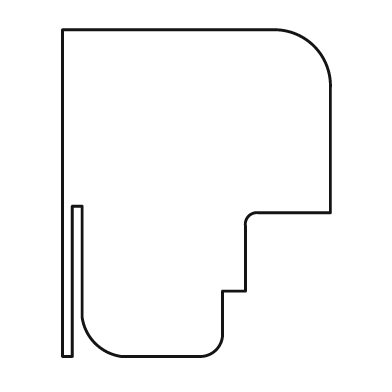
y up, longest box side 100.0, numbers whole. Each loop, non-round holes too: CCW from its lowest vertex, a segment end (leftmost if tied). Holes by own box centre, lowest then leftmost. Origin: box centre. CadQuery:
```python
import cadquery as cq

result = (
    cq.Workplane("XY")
    .moveTo(-41.0, -50.0)
    .lineTo(-38.0, -50.0)
    .lineTo(-38.0, -4.0)
    .lineTo(-35.0, -4.0)
    .lineTo(-35.0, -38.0)
    .threePointArc((-31.0, -46.0), (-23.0, -50.0))
    .lineTo(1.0, -50.0)
    .threePointArc((6.0, -48.0), (8.0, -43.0))
    .lineTo(8.0, -30.0)
    .lineTo(15.0, -30.0)
    .lineTo(15.0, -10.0)
    .threePointArc((16.0, -7.0), (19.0, -6.0))
    .lineTo(41.0, -6.0)
    .lineTo(41.0, 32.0)
    .threePointArc((36.0, 45.0), (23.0, 50.0))
    .lineTo(-41.0, 50.0)
    .close()
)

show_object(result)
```